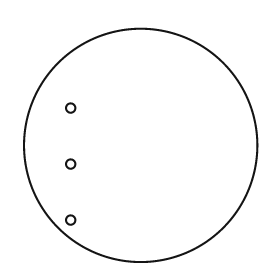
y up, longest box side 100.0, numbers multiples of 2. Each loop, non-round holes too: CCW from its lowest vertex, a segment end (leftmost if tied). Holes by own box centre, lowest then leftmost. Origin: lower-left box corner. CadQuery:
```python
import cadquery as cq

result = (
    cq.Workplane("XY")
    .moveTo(50.0, 50.0)
    .circle(50.0)
    .moveTo(20.0, 18.0)
    .circle(2.0)
    .moveTo(20.0, 42.0)
    .circle(2.0)
    .moveTo(20.0, 66.0)
    .circle(2.0)
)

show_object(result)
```